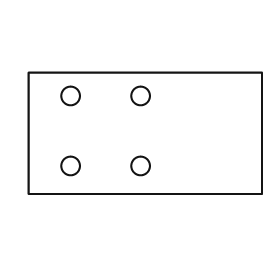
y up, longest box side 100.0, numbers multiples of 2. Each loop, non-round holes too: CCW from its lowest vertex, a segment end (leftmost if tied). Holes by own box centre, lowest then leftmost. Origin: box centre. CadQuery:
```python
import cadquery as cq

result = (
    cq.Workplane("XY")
    .moveTo(-50.0, -26.0)
    .lineTo(50.0, -26.0)
    .lineTo(50.0, 26.0)
    .lineTo(-50.0, 26.0)
    .close()
    .moveTo(-32.0, -14.0)
    .circle(4.0)
    .moveTo(-2.0, -14.0)
    .circle(4.0)
    .moveTo(-32.0, 16.0)
    .circle(4.0)
    .moveTo(-2.0, 16.0)
    .circle(4.0)
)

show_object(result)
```